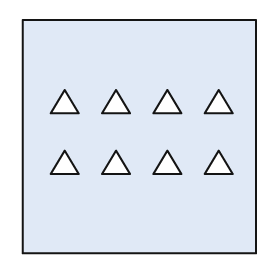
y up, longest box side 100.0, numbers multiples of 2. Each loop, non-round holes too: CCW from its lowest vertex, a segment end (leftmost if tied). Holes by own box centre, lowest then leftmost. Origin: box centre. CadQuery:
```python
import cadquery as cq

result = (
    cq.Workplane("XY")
    .moveTo(-50.0, -50.0)
    .lineTo(50.0, -50.0)
    .lineTo(50.0, 50.0)
    .lineTo(-50.0, 50.0)
    .close()
    .moveTo(-38.0, -16.0)
    .lineTo(-26.0, -16.0)
    .lineTo(-32.0, -6.0)
    .close()
    .moveTo(-16.0, -16.0)
    .lineTo(-4.0, -16.0)
    .lineTo(-10.0, -6.0)
    .close()
    .moveTo(6.0, -16.0)
    .lineTo(18.0, -16.0)
    .lineTo(12.0, -6.0)
    .close()
    .moveTo(28.0, -16.0)
    .lineTo(40.0, -16.0)
    .lineTo(34.0, -6.0)
    .close()
    .moveTo(-38.0, 10.0)
    .lineTo(-26.0, 10.0)
    .lineTo(-32.0, 20.0)
    .close()
    .moveTo(-16.0, 10.0)
    .lineTo(-4.0, 10.0)
    .lineTo(-10.0, 20.0)
    .close()
    .moveTo(6.0, 10.0)
    .lineTo(18.0, 10.0)
    .lineTo(12.0, 20.0)
    .close()
    .moveTo(28.0, 10.0)
    .lineTo(40.0, 10.0)
    .lineTo(34.0, 20.0)
    .close()
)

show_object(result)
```